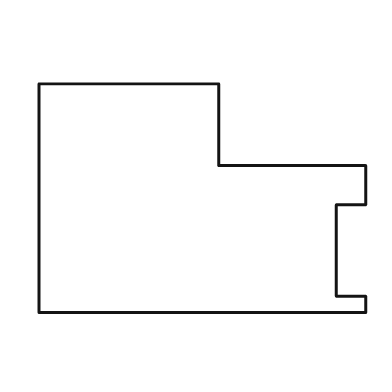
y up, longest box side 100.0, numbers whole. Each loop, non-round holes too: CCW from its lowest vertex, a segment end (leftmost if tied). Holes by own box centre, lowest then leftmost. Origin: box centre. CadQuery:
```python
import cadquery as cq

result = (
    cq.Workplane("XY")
    .moveTo(-50.0, -35.0)
    .lineTo(50.0, -35.0)
    .lineTo(50.0, -30.0)
    .lineTo(41.0, -30.0)
    .lineTo(41.0, -2.0)
    .lineTo(50.0, -2.0)
    .lineTo(50.0, 10.0)
    .lineTo(5.0, 10.0)
    .lineTo(5.0, 35.0)
    .lineTo(-50.0, 35.0)
    .close()
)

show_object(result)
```